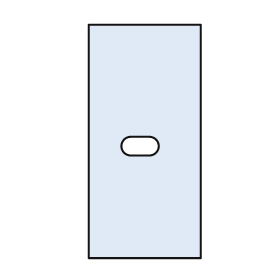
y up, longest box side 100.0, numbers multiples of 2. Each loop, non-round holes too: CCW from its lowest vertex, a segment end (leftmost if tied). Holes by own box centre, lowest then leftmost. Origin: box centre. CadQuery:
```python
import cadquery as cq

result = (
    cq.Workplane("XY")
    .moveTo(-24.0, -50.0)
    .lineTo(24.0, -50.0)
    .lineTo(24.0, 50.0)
    .lineTo(-24.0, 50.0)
    .close()
    .moveTo(-6.0, -6.0)
    .lineTo(2.0, -6.0)
    .threePointArc((6.0, -2.0), (2.0, 2.0))
    .lineTo(-6.0, 2.0)
    .threePointArc((-10.0, -2.0), (-6.0, -6.0))
    .close()
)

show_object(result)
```